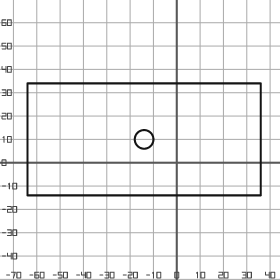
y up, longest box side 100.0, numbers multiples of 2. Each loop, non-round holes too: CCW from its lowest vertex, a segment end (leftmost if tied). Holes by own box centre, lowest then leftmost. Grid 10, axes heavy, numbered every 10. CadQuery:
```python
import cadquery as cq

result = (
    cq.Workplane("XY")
    .moveTo(-64.0, -14.0)
    .lineTo(36.0, -14.0)
    .lineTo(36.0, 34.0)
    .lineTo(-64.0, 34.0)
    .close()
    .moveTo(-14.0, 10.0)
    .circle(4.0)
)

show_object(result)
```